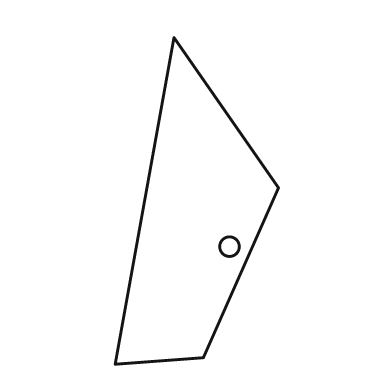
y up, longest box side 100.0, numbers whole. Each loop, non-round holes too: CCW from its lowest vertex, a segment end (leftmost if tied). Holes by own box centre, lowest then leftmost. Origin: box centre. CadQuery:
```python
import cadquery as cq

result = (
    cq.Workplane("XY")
    .moveTo(-25.0, -50.0)
    .lineTo(2.0, -48.0)
    .lineTo(25.0, 4.0)
    .lineTo(-7.0, 50.0)
    .close()
    .moveTo(10.0, -14.0)
    .circle(3.0)
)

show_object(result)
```